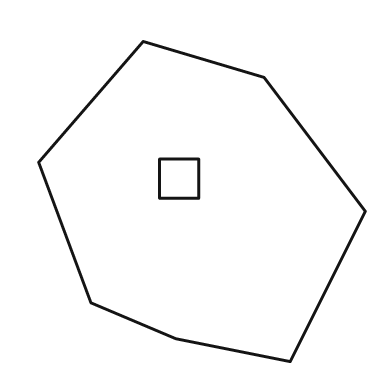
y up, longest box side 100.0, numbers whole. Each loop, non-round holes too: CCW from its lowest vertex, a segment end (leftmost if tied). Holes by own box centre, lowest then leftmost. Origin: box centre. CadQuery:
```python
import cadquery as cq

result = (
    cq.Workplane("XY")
    .moveTo(27.0, -49.0)
    .lineTo(50.0, -3.0)
    .lineTo(19.0, 38.0)
    .lineTo(-18.0, 49.0)
    .lineTo(-50.0, 12.0)
    .lineTo(-34.0, -31.0)
    .lineTo(-8.0, -42.0)
    .close()
    .moveTo(-13.0, 1.0)
    .lineTo(-1.0, 1.0)
    .lineTo(-1.0, 13.0)
    .lineTo(-13.0, 13.0)
    .close()
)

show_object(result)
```